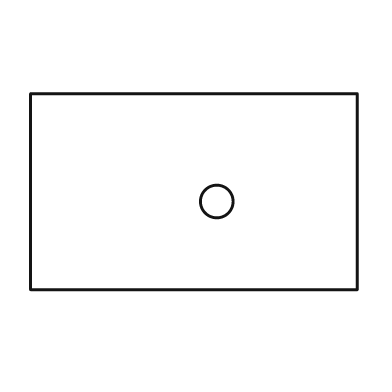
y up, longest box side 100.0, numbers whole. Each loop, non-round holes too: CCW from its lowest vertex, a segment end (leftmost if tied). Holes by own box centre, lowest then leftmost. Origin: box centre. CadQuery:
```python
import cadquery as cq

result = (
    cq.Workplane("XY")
    .moveTo(-50.0, -30.0)
    .lineTo(50.0, -30.0)
    .lineTo(50.0, 30.0)
    .lineTo(-50.0, 30.0)
    .close()
    .moveTo(7.0, -3.0)
    .circle(5.0)
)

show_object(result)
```